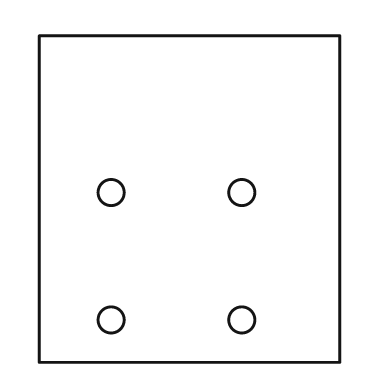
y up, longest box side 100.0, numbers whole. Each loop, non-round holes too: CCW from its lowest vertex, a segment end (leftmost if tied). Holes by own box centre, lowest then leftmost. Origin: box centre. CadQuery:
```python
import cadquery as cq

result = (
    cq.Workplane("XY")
    .moveTo(-46.0, -50.0)
    .lineTo(46.0, -50.0)
    .lineTo(46.0, 50.0)
    .lineTo(-46.0, 50.0)
    .close()
    .moveTo(-24.0, -37.0)
    .circle(4.0)
    .moveTo(16.0, -37.0)
    .circle(4.0)
    .moveTo(-24.0, 2.0)
    .circle(4.0)
    .moveTo(16.0, 2.0)
    .circle(4.0)
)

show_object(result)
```